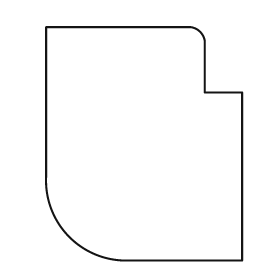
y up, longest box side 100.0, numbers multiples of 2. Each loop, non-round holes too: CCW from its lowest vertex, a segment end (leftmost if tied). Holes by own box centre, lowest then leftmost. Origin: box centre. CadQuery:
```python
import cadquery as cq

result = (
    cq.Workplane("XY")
    .moveTo(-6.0, -50.0)
    .lineTo(42.0, -50.0)
    .lineTo(42.0, 22.0)
    .lineTo(26.0, 22.0)
    .lineTo(26.0, 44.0)
    .threePointArc((24.0, 48.0), (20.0, 50.0))
    .lineTo(-42.0, 50.0)
    .lineTo(-42.0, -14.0)
    .threePointArc((-32.0, -40.0), (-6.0, -50.0))
    .close()
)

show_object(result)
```